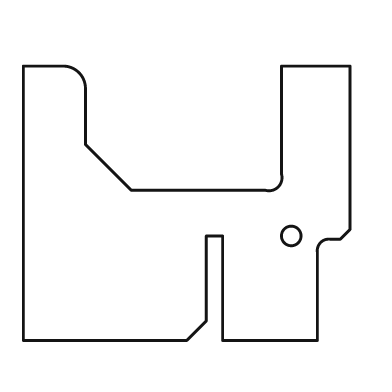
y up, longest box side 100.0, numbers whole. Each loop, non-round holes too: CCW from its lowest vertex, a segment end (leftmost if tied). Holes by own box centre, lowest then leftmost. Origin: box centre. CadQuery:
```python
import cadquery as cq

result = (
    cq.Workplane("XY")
    .moveTo(-50.0, -42.0)
    .lineTo(0.0, -42.0)
    .lineTo(6.0, -36.0)
    .lineTo(6.0, -10.0)
    .lineTo(11.0, -10.0)
    .lineTo(11.0, -42.0)
    .lineTo(40.0, -42.0)
    .lineTo(40.0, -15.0)
    .threePointArc((41.0, -12.0), (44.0, -11.0))
    .lineTo(47.0, -11.0)
    .lineTo(50.0, -8.0)
    .lineTo(50.0, 42.0)
    .lineTo(29.0, 42.0)
    .lineTo(29.0, 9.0)
    .threePointArc((28.0, 5.0), (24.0, 4.0))
    .lineTo(-17.0, 4.0)
    .lineTo(-31.0, 18.0)
    .lineTo(-31.0, 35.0)
    .threePointArc((-33.0, 40.0), (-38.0, 42.0))
    .lineTo(-50.0, 42.0)
    .close()
    .moveTo(32.0, -10.0)
    .circle(3.0)
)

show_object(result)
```